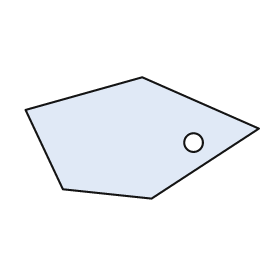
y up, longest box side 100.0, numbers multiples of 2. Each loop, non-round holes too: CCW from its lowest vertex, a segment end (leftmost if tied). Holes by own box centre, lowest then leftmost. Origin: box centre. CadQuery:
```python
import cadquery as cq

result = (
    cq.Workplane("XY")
    .moveTo(4.0, -26.0)
    .lineTo(50.0, 4.0)
    .lineTo(0.0, 26.0)
    .lineTo(-50.0, 12.0)
    .lineTo(-34.0, -22.0)
    .close()
    .moveTo(22.0, -2.0)
    .circle(4.0)
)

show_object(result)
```